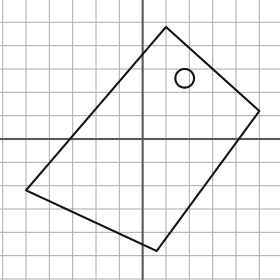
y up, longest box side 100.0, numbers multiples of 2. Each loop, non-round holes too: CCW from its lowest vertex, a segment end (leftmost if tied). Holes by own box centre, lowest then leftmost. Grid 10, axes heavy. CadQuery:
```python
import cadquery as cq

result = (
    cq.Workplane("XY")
    .moveTo(6.0, -48.0)
    .lineTo(50.0, 12.0)
    .lineTo(10.0, 48.0)
    .lineTo(-50.0, -22.0)
    .close()
    .moveTo(18.0, 26.0)
    .circle(4.0)
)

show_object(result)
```